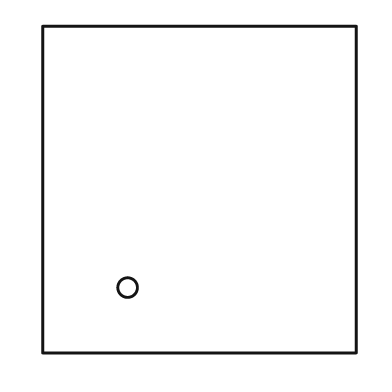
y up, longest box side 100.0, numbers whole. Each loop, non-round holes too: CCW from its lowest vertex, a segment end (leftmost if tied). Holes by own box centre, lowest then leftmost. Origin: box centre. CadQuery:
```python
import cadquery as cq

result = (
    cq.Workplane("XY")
    .moveTo(-48.0, -50.0)
    .lineTo(48.0, -50.0)
    .lineTo(48.0, 50.0)
    .lineTo(-48.0, 50.0)
    .close()
    .moveTo(-22.0, -30.0)
    .circle(3.0)
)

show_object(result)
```